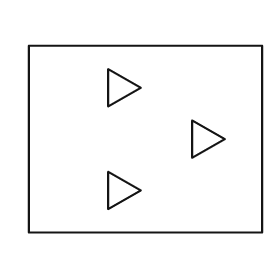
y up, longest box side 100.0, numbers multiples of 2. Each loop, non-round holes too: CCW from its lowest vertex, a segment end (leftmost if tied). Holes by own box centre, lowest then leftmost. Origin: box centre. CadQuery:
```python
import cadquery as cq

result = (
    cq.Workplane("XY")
    .moveTo(-50.0, -40.0)
    .lineTo(50.0, -40.0)
    .lineTo(50.0, 40.0)
    .lineTo(-50.0, 40.0)
    .close()
    .moveTo(-16.0, -30.0)
    .lineTo(-2.0, -22.0)
    .lineTo(-16.0, -14.0)
    .close()
    .moveTo(20.0, -8.0)
    .lineTo(34.0, 0.0)
    .lineTo(20.0, 8.0)
    .close()
    .moveTo(-16.0, 14.0)
    .lineTo(-2.0, 22.0)
    .lineTo(-16.0, 30.0)
    .close()
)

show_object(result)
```